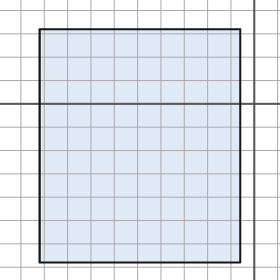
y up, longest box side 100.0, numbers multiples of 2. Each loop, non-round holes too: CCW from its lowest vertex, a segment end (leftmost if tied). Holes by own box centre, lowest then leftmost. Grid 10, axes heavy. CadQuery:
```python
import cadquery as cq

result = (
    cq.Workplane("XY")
    .moveTo(-92.0, -68.0)
    .lineTo(-6.0, -68.0)
    .lineTo(-6.0, 32.0)
    .lineTo(-92.0, 32.0)
    .close()
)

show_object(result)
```